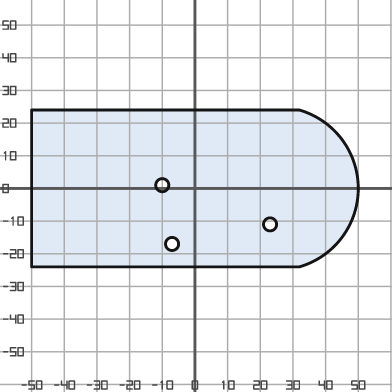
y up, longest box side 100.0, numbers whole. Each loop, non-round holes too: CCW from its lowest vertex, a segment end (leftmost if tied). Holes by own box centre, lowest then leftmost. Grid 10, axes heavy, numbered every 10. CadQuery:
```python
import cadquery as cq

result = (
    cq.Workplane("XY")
    .moveTo(-50.0, -24.0)
    .lineTo(32.0, -24.0)
    .threePointArc((50.0, 0.0), (32.0, 24.0))
    .lineTo(-50.0, 24.0)
    .close()
    .moveTo(-7.0, -17.0)
    .circle(2.0)
    .moveTo(23.0, -11.0)
    .circle(2.0)
    .moveTo(-10.0, 1.0)
    .circle(2.0)
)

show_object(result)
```